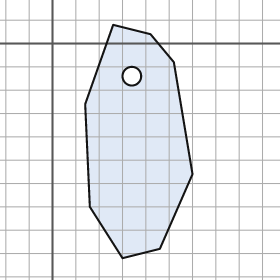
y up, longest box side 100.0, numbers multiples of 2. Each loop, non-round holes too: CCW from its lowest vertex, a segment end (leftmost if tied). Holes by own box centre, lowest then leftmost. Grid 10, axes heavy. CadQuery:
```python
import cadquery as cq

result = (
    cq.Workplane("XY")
    .moveTo(30.0, -92.0)
    .lineTo(46.0, -88.0)
    .lineTo(60.0, -56.0)
    .lineTo(52.0, -8.0)
    .lineTo(42.0, 4.0)
    .lineTo(26.0, 8.0)
    .lineTo(14.0, -26.0)
    .lineTo(16.0, -70.0)
    .close()
    .moveTo(34.0, -14.0)
    .circle(4.0)
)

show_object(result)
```